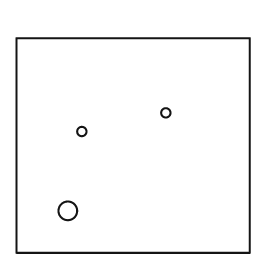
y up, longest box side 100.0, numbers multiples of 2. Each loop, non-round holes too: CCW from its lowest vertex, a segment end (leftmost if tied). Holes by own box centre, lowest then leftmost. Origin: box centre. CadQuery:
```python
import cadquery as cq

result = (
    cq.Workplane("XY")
    .moveTo(-50.0, -46.0)
    .lineTo(50.0, -46.0)
    .lineTo(50.0, 46.0)
    .lineTo(-50.0, 46.0)
    .close()
    .moveTo(-28.0, -28.0)
    .circle(4.0)
    .moveTo(-22.0, 6.0)
    .circle(2.0)
    .moveTo(14.0, 14.0)
    .circle(2.0)
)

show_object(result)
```